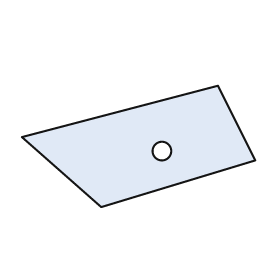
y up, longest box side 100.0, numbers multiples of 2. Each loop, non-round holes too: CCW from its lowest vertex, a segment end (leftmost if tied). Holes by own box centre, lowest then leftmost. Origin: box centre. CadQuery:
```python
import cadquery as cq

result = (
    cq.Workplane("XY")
    .moveTo(-16.0, -26.0)
    .lineTo(50.0, -6.0)
    .lineTo(34.0, 26.0)
    .lineTo(-50.0, 4.0)
    .close()
    .moveTo(10.0, -2.0)
    .circle(4.0)
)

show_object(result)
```